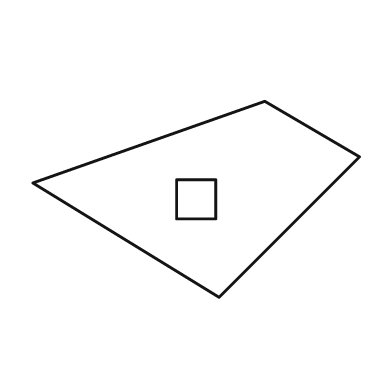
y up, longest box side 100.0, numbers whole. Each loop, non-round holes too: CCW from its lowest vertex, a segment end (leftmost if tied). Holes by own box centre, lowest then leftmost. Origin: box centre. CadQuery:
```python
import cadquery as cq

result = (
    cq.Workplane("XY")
    .moveTo(7.0, -30.0)
    .lineTo(50.0, 13.0)
    .lineTo(21.0, 30.0)
    .lineTo(-50.0, 5.0)
    .close()
    .moveTo(-6.0, -6.0)
    .lineTo(6.0, -6.0)
    .lineTo(6.0, 6.0)
    .lineTo(-6.0, 6.0)
    .close()
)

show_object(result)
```